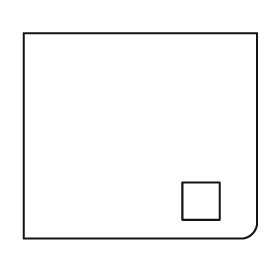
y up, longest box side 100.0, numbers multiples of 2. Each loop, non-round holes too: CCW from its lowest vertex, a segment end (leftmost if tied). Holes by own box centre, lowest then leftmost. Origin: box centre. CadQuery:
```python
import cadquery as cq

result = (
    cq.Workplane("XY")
    .moveTo(-50.0, -44.0)
    .lineTo(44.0, -44.0)
    .threePointArc((48.0, -42.0), (50.0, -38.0))
    .lineTo(50.0, 44.0)
    .lineTo(-50.0, 44.0)
    .close()
    .moveTo(18.0, -36.0)
    .lineTo(34.0, -36.0)
    .lineTo(34.0, -20.0)
    .lineTo(18.0, -20.0)
    .close()
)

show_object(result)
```